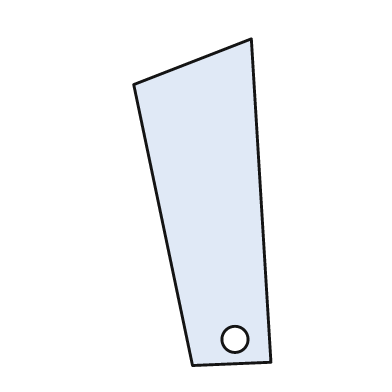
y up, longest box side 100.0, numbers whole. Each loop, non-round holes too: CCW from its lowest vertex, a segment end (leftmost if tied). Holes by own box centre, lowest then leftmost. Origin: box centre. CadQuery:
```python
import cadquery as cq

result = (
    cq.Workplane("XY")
    .moveTo(-3.0, -50.0)
    .lineTo(21.0, -49.0)
    .lineTo(15.0, 50.0)
    .lineTo(-21.0, 36.0)
    .close()
    .moveTo(10.0, -42.0)
    .circle(4.0)
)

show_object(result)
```